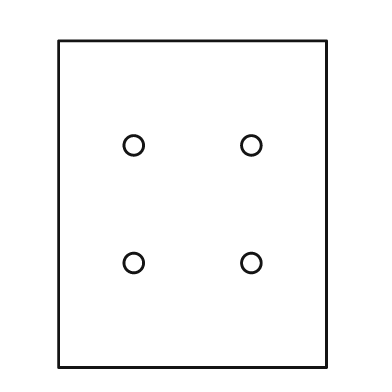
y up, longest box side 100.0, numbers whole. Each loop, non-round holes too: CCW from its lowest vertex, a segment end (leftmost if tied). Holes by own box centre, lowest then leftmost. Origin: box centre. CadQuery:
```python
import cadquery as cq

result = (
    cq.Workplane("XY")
    .moveTo(-41.0, -50.0)
    .lineTo(41.0, -50.0)
    .lineTo(41.0, 50.0)
    .lineTo(-41.0, 50.0)
    .close()
    .moveTo(-18.0, -18.0)
    .circle(3.0)
    .moveTo(18.0, -18.0)
    .circle(3.0)
    .moveTo(-18.0, 18.0)
    .circle(3.0)
    .moveTo(18.0, 18.0)
    .circle(3.0)
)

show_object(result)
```